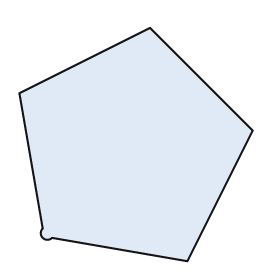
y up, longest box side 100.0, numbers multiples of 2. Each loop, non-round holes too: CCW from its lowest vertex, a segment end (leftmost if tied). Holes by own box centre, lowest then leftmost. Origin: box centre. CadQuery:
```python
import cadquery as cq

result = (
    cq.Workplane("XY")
    .moveTo(22.0, -50.0)
    .lineTo(50.0, 6.0)
    .lineTo(6.0, 50.0)
    .lineTo(-50.0, 22.0)
    .lineTo(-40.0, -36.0)
    .threePointArc((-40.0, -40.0), (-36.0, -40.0))
    .close()
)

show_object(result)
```